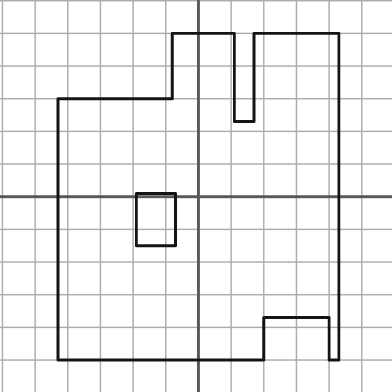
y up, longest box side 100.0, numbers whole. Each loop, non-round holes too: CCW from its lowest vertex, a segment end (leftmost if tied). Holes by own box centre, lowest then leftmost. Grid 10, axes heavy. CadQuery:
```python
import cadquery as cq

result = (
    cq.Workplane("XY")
    .moveTo(-43.0, -50.0)
    .lineTo(20.0, -50.0)
    .lineTo(20.0, -37.0)
    .lineTo(40.0, -37.0)
    .lineTo(40.0, -50.0)
    .lineTo(43.0, -50.0)
    .lineTo(43.0, 50.0)
    .lineTo(17.0, 50.0)
    .lineTo(17.0, 23.0)
    .lineTo(11.0, 23.0)
    .lineTo(11.0, 50.0)
    .lineTo(-8.0, 50.0)
    .lineTo(-8.0, 30.0)
    .lineTo(-43.0, 30.0)
    .close()
    .moveTo(-19.0, -15.0)
    .lineTo(-7.0, -15.0)
    .lineTo(-7.0, 1.0)
    .lineTo(-19.0, 1.0)
    .close()
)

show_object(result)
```